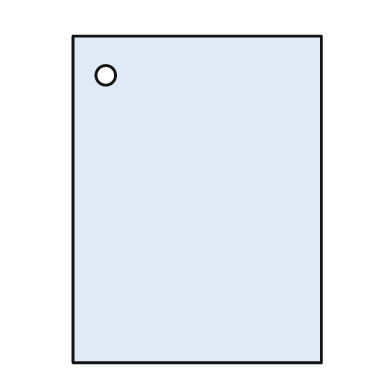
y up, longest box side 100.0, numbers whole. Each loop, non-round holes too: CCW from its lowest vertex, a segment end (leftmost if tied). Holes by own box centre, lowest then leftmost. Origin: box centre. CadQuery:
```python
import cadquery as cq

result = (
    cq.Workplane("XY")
    .moveTo(-38.0, -50.0)
    .lineTo(38.0, -50.0)
    .lineTo(38.0, 50.0)
    .lineTo(-38.0, 50.0)
    .close()
    .moveTo(-28.0, 38.0)
    .circle(3.0)
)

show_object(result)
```